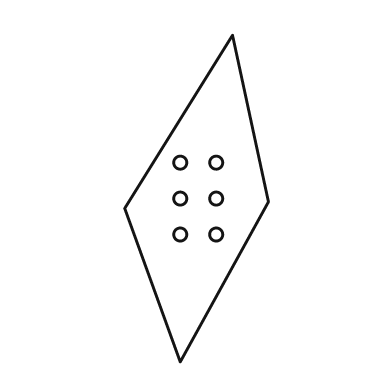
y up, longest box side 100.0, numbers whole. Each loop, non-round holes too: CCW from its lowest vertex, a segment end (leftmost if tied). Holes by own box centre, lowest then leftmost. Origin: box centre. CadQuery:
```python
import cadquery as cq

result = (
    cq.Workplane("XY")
    .moveTo(-5.0, -50.0)
    .lineTo(22.0, -1.0)
    .lineTo(11.0, 50.0)
    .lineTo(-22.0, -3.0)
    .close()
    .moveTo(-5.0, -11.0)
    .circle(2.0)
    .moveTo(6.0, -11.0)
    .circle(2.0)
    .moveTo(-5.0, 0.0)
    .circle(2.0)
    .moveTo(6.0, 0.0)
    .circle(2.0)
    .moveTo(-5.0, 11.0)
    .circle(2.0)
    .moveTo(6.0, 11.0)
    .circle(2.0)
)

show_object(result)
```